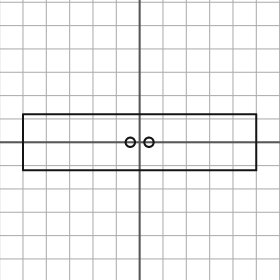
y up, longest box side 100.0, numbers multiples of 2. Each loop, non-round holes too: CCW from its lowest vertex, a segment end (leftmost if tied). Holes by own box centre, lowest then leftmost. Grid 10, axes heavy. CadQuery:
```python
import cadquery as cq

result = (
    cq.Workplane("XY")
    .moveTo(-50.0, -12.0)
    .lineTo(50.0, -12.0)
    .lineTo(50.0, 12.0)
    .lineTo(-50.0, 12.0)
    .close()
    .moveTo(-4.0, 0.0)
    .circle(2.0)
    .moveTo(4.0, 0.0)
    .circle(2.0)
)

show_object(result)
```